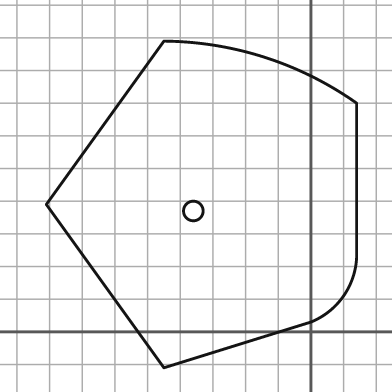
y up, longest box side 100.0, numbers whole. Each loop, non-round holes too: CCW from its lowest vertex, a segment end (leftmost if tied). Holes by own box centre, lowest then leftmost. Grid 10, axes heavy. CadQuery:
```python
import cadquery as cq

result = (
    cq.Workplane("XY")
    .moveTo(-45.0, -11.0)
    .lineTo(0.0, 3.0)
    .threePointArc((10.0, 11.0), (14.0, 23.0))
    .lineTo(14.0, 70.0)
    .threePointArc((-14.0, 84.0), (-45.0, 89.0))
    .lineTo(-81.0, 39.0)
    .close()
    .moveTo(-36.0, 37.0)
    .circle(3.0)
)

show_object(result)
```